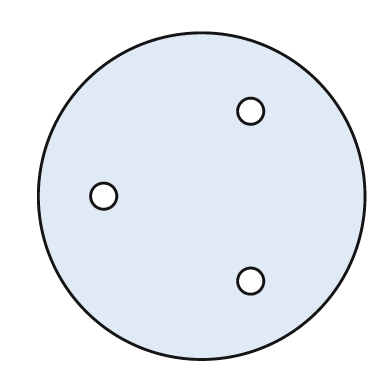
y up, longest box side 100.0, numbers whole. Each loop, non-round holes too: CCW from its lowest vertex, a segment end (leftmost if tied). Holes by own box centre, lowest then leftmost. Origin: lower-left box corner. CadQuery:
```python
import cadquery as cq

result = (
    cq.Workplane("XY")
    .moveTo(50.0, 50.0)
    .circle(50.0)
    .moveTo(65.0, 24.0)
    .circle(4.0)
    .moveTo(20.0, 50.0)
    .circle(4.0)
    .moveTo(65.0, 76.0)
    .circle(4.0)
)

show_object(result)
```